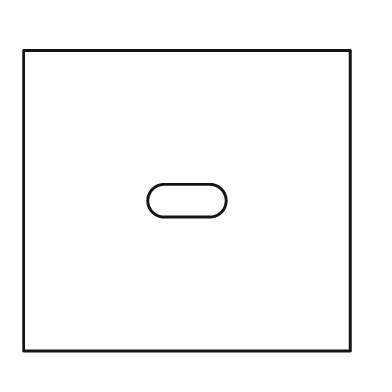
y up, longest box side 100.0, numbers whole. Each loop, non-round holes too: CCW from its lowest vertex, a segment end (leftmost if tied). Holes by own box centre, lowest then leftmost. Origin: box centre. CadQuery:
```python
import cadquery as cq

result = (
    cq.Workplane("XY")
    .moveTo(-50.0, -46.0)
    .lineTo(50.0, -46.0)
    .lineTo(50.0, 46.0)
    .lineTo(-50.0, 46.0)
    .close()
    .moveTo(-7.0, -5.0)
    .lineTo(7.0, -5.0)
    .threePointArc((12.0, 0.0), (7.0, 5.0))
    .lineTo(-7.0, 5.0)
    .threePointArc((-12.0, 0.0), (-7.0, -5.0))
    .close()
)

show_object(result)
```